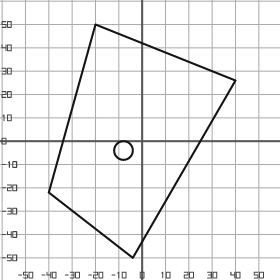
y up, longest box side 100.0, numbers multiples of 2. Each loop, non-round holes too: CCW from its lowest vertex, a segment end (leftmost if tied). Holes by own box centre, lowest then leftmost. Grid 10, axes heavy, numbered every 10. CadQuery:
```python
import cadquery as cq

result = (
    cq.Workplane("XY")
    .moveTo(-4.0, -50.0)
    .lineTo(40.0, 26.0)
    .lineTo(-20.0, 50.0)
    .lineTo(-40.0, -22.0)
    .close()
    .moveTo(-8.0, -4.0)
    .circle(4.0)
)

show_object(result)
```